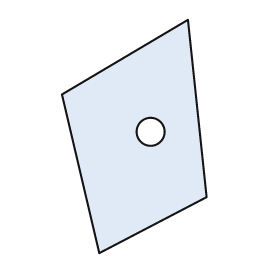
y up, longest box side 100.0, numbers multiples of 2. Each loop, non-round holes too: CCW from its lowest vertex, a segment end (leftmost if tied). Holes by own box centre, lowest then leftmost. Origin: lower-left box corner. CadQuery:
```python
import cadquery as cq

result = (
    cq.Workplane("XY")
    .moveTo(16.0, 0.0)
    .lineTo(62.0, 24.0)
    .lineTo(54.0, 100.0)
    .lineTo(0.0, 68.0)
    .close()
    .moveTo(38.0, 52.0)
    .circle(6.0)
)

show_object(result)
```